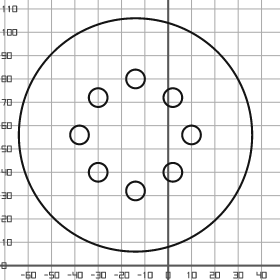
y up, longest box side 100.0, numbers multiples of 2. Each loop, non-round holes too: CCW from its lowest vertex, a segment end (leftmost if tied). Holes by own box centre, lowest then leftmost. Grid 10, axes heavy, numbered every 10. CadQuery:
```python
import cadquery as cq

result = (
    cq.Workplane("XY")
    .moveTo(-14.0, 56.0)
    .circle(50.0)
    .moveTo(-14.0, 32.0)
    .circle(4.0)
    .moveTo(-30.0, 40.0)
    .circle(4.0)
    .moveTo(2.0, 40.0)
    .circle(4.0)
    .moveTo(-38.0, 56.0)
    .circle(4.0)
    .moveTo(10.0, 56.0)
    .circle(4.0)
    .moveTo(-30.0, 72.0)
    .circle(4.0)
    .moveTo(2.0, 72.0)
    .circle(4.0)
    .moveTo(-14.0, 80.0)
    .circle(4.0)
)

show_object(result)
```